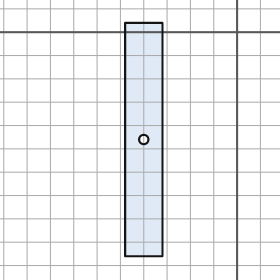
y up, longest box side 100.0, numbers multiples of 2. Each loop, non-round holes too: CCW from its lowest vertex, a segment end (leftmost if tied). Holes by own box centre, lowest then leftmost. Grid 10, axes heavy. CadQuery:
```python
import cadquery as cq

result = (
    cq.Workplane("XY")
    .moveTo(-48.0, -96.0)
    .lineTo(-32.0, -96.0)
    .lineTo(-32.0, 4.0)
    .lineTo(-48.0, 4.0)
    .close()
    .moveTo(-40.0, -46.0)
    .circle(2.0)
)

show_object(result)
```